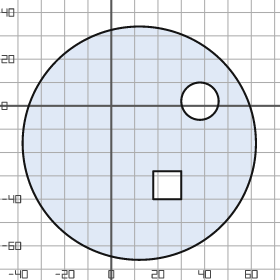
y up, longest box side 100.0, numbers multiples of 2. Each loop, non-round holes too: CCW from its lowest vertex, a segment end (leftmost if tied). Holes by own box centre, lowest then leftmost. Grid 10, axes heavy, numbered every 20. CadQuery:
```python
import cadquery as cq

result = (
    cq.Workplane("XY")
    .moveTo(12.0, -16.0)
    .circle(50.0)
    .moveTo(18.0, -40.0)
    .lineTo(30.0, -40.0)
    .lineTo(30.0, -28.0)
    .lineTo(18.0, -28.0)
    .close()
    .moveTo(38.0, 2.0)
    .circle(8.0)
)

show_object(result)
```